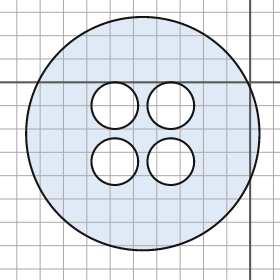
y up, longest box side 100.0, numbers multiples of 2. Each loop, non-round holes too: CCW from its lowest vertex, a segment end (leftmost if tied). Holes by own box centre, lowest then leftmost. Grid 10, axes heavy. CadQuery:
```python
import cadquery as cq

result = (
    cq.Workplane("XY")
    .moveTo(-46.0, -22.0)
    .circle(50.0)
    .moveTo(-58.0, -34.0)
    .circle(10.0)
    .moveTo(-34.0, -34.0)
    .circle(10.0)
    .moveTo(-58.0, -10.0)
    .circle(10.0)
    .moveTo(-34.0, -10.0)
    .circle(10.0)
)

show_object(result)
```